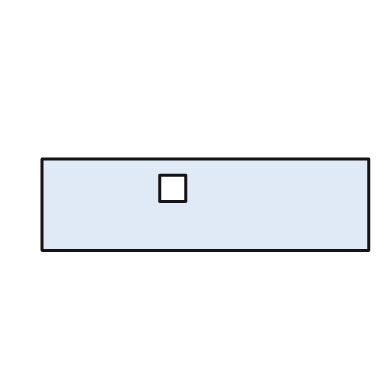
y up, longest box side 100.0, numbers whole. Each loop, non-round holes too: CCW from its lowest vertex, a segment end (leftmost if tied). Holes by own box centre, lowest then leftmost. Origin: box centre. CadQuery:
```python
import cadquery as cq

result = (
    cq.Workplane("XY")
    .moveTo(-50.0, -14.0)
    .lineTo(50.0, -14.0)
    .lineTo(50.0, 14.0)
    .lineTo(-50.0, 14.0)
    .close()
    .moveTo(-14.0, 1.0)
    .lineTo(-6.0, 1.0)
    .lineTo(-6.0, 9.0)
    .lineTo(-14.0, 9.0)
    .close()
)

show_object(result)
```